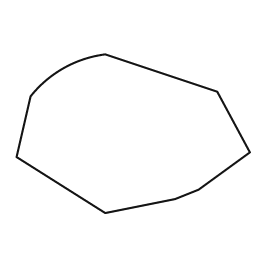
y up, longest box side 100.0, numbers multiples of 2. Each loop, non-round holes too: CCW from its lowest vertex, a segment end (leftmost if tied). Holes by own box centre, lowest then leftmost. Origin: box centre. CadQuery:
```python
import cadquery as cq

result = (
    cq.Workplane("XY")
    .moveTo(-12.0, -34.0)
    .lineTo(18.0, -28.0)
    .lineTo(28.0, -24.0)
    .lineTo(50.0, -8.0)
    .lineTo(36.0, 18.0)
    .lineTo(-12.0, 34.0)
    .threePointArc((-30.0, 28.0), (-44.0, 16.0))
    .lineTo(-50.0, -10.0)
    .close()
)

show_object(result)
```